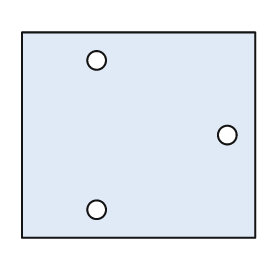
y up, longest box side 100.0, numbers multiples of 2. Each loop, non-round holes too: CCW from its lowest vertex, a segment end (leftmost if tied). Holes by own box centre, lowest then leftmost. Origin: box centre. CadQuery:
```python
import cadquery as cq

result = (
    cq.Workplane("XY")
    .moveTo(-50.0, -44.0)
    .lineTo(50.0, -44.0)
    .lineTo(50.0, 44.0)
    .lineTo(-50.0, 44.0)
    .close()
    .moveTo(-18.0, -32.0)
    .circle(4.0)
    .moveTo(38.0, 0.0)
    .circle(4.0)
    .moveTo(-18.0, 32.0)
    .circle(4.0)
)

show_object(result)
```